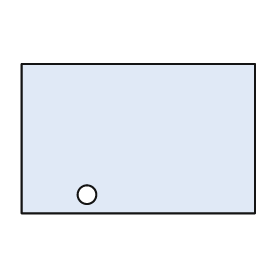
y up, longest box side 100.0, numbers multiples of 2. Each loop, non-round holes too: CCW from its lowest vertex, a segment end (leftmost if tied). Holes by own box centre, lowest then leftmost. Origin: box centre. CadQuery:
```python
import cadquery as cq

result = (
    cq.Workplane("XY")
    .moveTo(-50.0, -32.0)
    .lineTo(50.0, -32.0)
    .lineTo(50.0, 32.0)
    .lineTo(-50.0, 32.0)
    .close()
    .moveTo(-22.0, -24.0)
    .circle(4.0)
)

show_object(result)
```